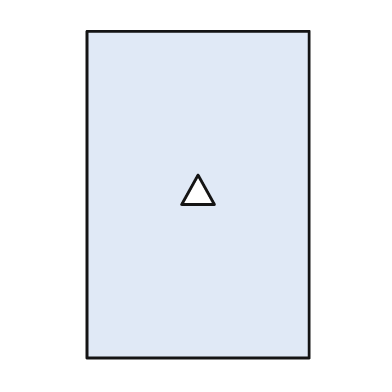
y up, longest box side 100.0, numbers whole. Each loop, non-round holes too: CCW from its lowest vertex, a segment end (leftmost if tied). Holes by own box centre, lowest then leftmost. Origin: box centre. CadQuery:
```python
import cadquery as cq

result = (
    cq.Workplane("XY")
    .moveTo(-34.0, -50.0)
    .lineTo(34.0, -50.0)
    .lineTo(34.0, 50.0)
    .lineTo(-34.0, 50.0)
    .close()
    .moveTo(-5.0, -3.0)
    .lineTo(5.0, -3.0)
    .lineTo(0.0, 6.0)
    .close()
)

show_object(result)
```